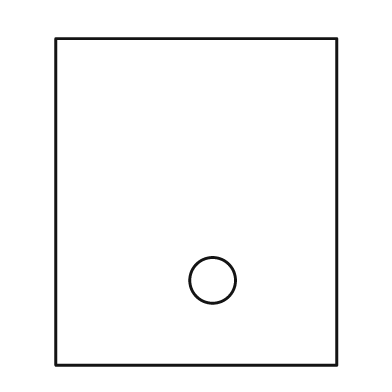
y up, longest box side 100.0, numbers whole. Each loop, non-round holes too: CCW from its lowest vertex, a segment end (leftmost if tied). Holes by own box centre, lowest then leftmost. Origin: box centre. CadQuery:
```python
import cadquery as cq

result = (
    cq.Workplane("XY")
    .moveTo(-43.0, -50.0)
    .lineTo(43.0, -50.0)
    .lineTo(43.0, 50.0)
    .lineTo(-43.0, 50.0)
    .close()
    .moveTo(5.0, -24.0)
    .circle(7.0)
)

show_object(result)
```